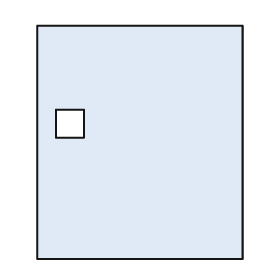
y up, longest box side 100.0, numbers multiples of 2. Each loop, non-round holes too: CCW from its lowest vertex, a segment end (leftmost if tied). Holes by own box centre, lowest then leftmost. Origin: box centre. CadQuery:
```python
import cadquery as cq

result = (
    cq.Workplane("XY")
    .moveTo(-44.0, -50.0)
    .lineTo(44.0, -50.0)
    .lineTo(44.0, 50.0)
    .lineTo(-44.0, 50.0)
    .close()
    .moveTo(-36.0, 2.0)
    .lineTo(-24.0, 2.0)
    .lineTo(-24.0, 14.0)
    .lineTo(-36.0, 14.0)
    .close()
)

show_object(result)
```